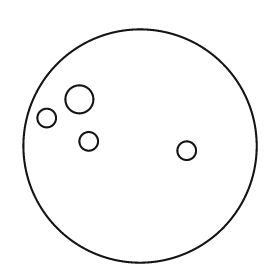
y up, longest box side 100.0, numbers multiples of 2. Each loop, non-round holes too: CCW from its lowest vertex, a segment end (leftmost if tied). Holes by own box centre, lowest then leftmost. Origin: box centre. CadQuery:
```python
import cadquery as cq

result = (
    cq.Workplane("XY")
    .moveTo(0.0, 0.0)
    .circle(50.0)
    .moveTo(20.0, -2.0)
    .circle(4.0)
    .moveTo(-22.0, 2.0)
    .circle(4.0)
    .moveTo(-40.0, 12.0)
    .circle(4.0)
    .moveTo(-26.0, 20.0)
    .circle(6.0)
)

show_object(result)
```